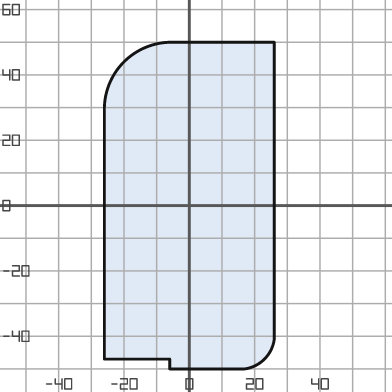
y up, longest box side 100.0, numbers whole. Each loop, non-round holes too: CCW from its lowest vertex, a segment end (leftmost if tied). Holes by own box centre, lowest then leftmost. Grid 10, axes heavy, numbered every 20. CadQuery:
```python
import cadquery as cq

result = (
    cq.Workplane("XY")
    .moveTo(-6.0, -50.0)
    .lineTo(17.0, -50.0)
    .threePointArc((23.0, -47.0), (26.0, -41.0))
    .lineTo(26.0, 50.0)
    .lineTo(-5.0, 50.0)
    .threePointArc((-20.0, 44.0), (-26.0, 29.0))
    .lineTo(-26.0, -47.0)
    .lineTo(-6.0, -47.0)
    .close()
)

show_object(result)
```